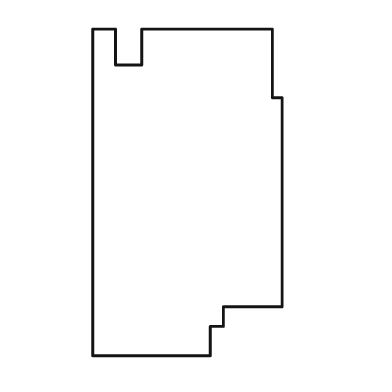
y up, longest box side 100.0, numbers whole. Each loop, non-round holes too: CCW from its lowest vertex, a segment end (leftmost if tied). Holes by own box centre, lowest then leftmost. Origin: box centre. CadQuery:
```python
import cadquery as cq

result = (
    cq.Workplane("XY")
    .moveTo(-29.0, -50.0)
    .lineTo(7.0, -50.0)
    .lineTo(7.0, -41.0)
    .lineTo(11.0, -41.0)
    .lineTo(11.0, -35.0)
    .lineTo(29.0, -35.0)
    .lineTo(29.0, 29.0)
    .lineTo(26.0, 29.0)
    .lineTo(26.0, 50.0)
    .lineTo(-14.0, 50.0)
    .lineTo(-14.0, 39.0)
    .lineTo(-22.0, 39.0)
    .lineTo(-22.0, 50.0)
    .lineTo(-29.0, 50.0)
    .close()
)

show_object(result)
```